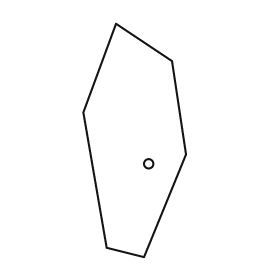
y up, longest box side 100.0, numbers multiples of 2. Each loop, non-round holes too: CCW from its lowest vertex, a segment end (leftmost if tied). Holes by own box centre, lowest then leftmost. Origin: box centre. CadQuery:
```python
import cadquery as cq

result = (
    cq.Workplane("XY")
    .moveTo(4.0, -50.0)
    .lineTo(22.0, -6.0)
    .lineTo(16.0, 34.0)
    .lineTo(-8.0, 50.0)
    .lineTo(-22.0, 12.0)
    .lineTo(-12.0, -46.0)
    .close()
    .moveTo(6.0, -10.0)
    .circle(2.0)
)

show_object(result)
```